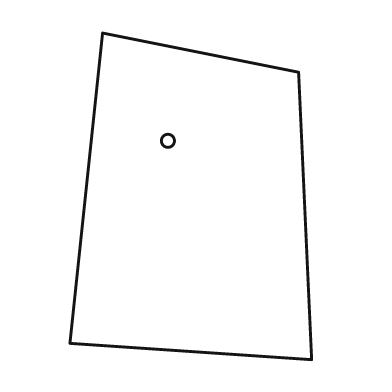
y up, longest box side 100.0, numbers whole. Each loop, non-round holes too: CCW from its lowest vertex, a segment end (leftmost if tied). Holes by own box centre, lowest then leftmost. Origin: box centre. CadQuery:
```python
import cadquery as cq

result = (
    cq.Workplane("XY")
    .moveTo(37.0, -50.0)
    .lineTo(33.0, 38.0)
    .lineTo(-27.0, 50.0)
    .lineTo(-37.0, -45.0)
    .close()
    .moveTo(-7.0, 17.0)
    .circle(2.0)
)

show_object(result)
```